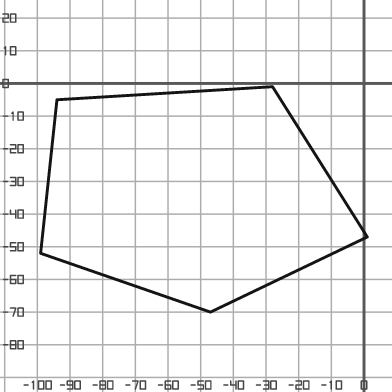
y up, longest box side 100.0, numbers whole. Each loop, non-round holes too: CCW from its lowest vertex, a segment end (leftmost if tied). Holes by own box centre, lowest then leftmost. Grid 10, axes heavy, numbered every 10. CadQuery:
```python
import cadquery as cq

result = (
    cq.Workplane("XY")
    .moveTo(-47.0, -70.0)
    .lineTo(1.0, -47.0)
    .lineTo(-28.0, -1.0)
    .lineTo(-94.0, -5.0)
    .lineTo(-99.0, -52.0)
    .close()
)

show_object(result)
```